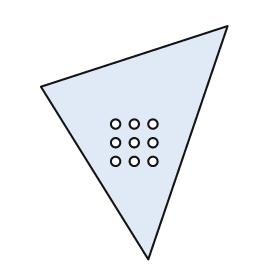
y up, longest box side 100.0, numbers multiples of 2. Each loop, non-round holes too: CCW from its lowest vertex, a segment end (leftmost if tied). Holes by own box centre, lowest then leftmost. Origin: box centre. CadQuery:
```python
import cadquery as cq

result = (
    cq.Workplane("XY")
    .moveTo(6.0, -50.0)
    .lineTo(40.0, 50.0)
    .lineTo(-40.0, 24.0)
    .close()
    .moveTo(-8.0, -8.0)
    .circle(2.0)
    .moveTo(0.0, -8.0)
    .circle(2.0)
    .moveTo(8.0, -8.0)
    .circle(2.0)
    .moveTo(-8.0, 0.0)
    .circle(2.0)
    .moveTo(0.0, 0.0)
    .circle(2.0)
    .moveTo(8.0, 0.0)
    .circle(2.0)
    .moveTo(-8.0, 8.0)
    .circle(2.0)
    .moveTo(0.0, 8.0)
    .circle(2.0)
    .moveTo(8.0, 8.0)
    .circle(2.0)
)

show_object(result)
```